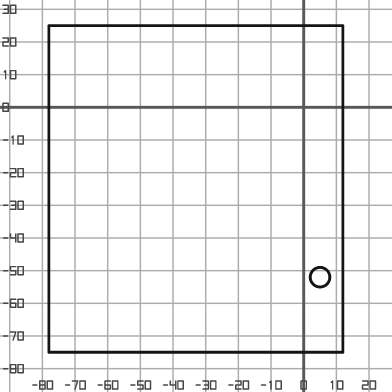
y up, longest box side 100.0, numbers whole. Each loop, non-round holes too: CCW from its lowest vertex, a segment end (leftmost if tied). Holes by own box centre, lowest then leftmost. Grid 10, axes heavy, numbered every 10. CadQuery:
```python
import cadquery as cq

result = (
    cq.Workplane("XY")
    .moveTo(-78.0, -75.0)
    .lineTo(12.0, -75.0)
    .lineTo(12.0, 25.0)
    .lineTo(-78.0, 25.0)
    .close()
    .moveTo(5.0, -52.0)
    .circle(3.0)
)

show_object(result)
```